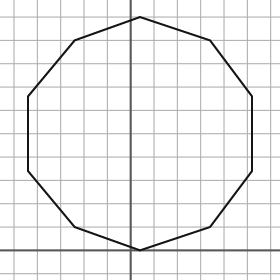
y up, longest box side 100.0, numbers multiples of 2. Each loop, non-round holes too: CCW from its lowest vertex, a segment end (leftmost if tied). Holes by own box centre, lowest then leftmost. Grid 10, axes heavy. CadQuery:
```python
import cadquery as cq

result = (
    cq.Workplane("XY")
    .moveTo(4.0, 0.0)
    .lineTo(34.0, 10.0)
    .lineTo(52.0, 34.0)
    .lineTo(52.0, 66.0)
    .lineTo(34.0, 90.0)
    .lineTo(4.0, 100.0)
    .lineTo(-24.0, 90.0)
    .lineTo(-44.0, 66.0)
    .lineTo(-44.0, 34.0)
    .lineTo(-24.0, 10.0)
    .close()
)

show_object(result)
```